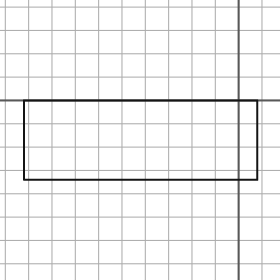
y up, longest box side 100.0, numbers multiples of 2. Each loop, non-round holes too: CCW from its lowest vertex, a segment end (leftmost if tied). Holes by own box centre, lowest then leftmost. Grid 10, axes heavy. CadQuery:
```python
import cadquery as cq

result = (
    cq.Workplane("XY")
    .moveTo(-92.0, -34.0)
    .lineTo(8.0, -34.0)
    .lineTo(8.0, 0.0)
    .lineTo(-92.0, 0.0)
    .close()
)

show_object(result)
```